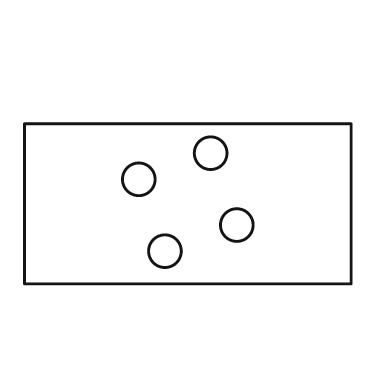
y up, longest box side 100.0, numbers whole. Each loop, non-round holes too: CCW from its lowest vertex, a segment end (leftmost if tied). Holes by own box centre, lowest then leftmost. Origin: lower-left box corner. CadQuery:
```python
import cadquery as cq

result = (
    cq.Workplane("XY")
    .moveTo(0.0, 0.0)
    .lineTo(100.0, 0.0)
    .lineTo(100.0, 49.0)
    .lineTo(0.0, 49.0)
    .close()
    .moveTo(43.0, 10.0)
    .circle(5.0)
    .moveTo(65.0, 18.0)
    .circle(5.0)
    .moveTo(35.0, 32.0)
    .circle(5.0)
    .moveTo(57.0, 40.0)
    .circle(5.0)
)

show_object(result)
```